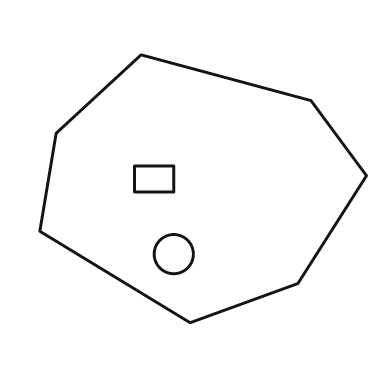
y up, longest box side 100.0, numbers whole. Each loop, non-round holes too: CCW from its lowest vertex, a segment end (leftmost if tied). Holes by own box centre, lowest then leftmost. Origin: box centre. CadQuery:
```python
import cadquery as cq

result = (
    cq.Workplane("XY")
    .moveTo(-4.0, -41.0)
    .lineTo(29.0, -29.0)
    .lineTo(50.0, 4.0)
    .lineTo(33.0, 27.0)
    .lineTo(-19.0, 41.0)
    .lineTo(-45.0, 17.0)
    .lineTo(-50.0, -13.0)
    .close()
    .moveTo(-9.0, -20.0)
    .circle(6.0)
    .moveTo(-21.0, -1.0)
    .lineTo(-9.0, -1.0)
    .lineTo(-9.0, 7.0)
    .lineTo(-21.0, 7.0)
    .close()
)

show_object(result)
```